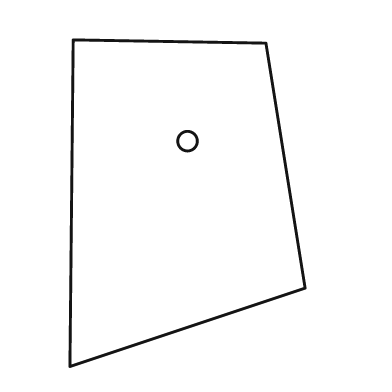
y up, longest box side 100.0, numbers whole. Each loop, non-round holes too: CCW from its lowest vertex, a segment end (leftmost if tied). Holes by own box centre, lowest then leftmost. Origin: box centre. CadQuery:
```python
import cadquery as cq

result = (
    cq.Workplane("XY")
    .moveTo(-36.0, -50.0)
    .lineTo(36.0, -26.0)
    .lineTo(24.0, 49.0)
    .lineTo(-35.0, 50.0)
    .close()
    .moveTo(0.0, 19.0)
    .circle(3.0)
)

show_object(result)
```